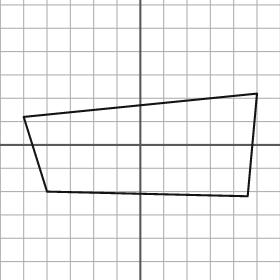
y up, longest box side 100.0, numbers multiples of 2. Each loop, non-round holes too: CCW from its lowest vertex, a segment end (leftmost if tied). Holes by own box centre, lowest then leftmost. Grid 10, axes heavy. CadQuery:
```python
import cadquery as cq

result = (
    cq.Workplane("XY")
    .moveTo(46.0, -22.0)
    .lineTo(50.0, 22.0)
    .lineTo(-50.0, 12.0)
    .lineTo(-40.0, -20.0)
    .close()
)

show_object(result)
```